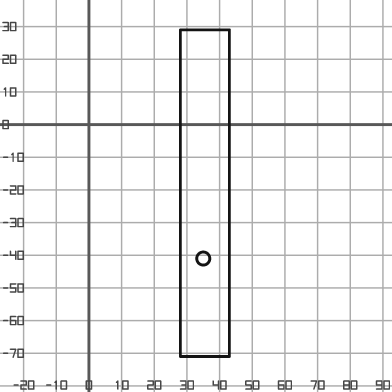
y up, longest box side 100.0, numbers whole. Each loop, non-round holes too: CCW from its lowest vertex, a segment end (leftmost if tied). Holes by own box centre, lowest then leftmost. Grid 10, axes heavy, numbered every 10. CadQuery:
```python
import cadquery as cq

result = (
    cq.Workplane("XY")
    .moveTo(28.0, -71.0)
    .lineTo(43.0, -71.0)
    .lineTo(43.0, 29.0)
    .lineTo(28.0, 29.0)
    .close()
    .moveTo(35.0, -41.0)
    .circle(2.0)
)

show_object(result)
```